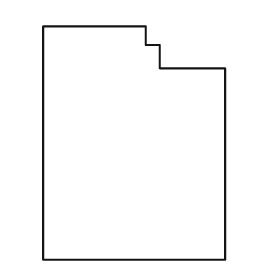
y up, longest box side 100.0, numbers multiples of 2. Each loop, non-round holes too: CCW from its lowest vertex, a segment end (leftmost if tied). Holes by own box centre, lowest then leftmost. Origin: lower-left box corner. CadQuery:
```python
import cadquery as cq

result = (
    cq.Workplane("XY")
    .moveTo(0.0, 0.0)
    .lineTo(78.0, 0.0)
    .lineTo(78.0, 82.0)
    .lineTo(50.0, 82.0)
    .lineTo(50.0, 92.0)
    .lineTo(44.0, 92.0)
    .lineTo(44.0, 100.0)
    .lineTo(0.0, 100.0)
    .close()
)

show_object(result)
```